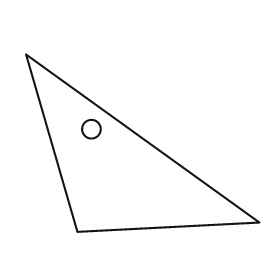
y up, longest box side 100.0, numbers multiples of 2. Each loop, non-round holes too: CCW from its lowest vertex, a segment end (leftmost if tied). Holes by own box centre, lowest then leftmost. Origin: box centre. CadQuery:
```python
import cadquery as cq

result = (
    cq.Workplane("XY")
    .moveTo(-28.0, -38.0)
    .lineTo(50.0, -34.0)
    .lineTo(-50.0, 38.0)
    .close()
    .moveTo(-22.0, 6.0)
    .circle(4.0)
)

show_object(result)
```